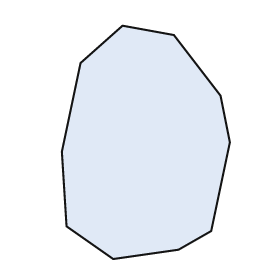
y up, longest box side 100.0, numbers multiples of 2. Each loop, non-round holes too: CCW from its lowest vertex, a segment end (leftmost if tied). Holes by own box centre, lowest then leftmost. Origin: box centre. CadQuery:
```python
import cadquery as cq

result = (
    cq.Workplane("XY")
    .moveTo(-14.0, -50.0)
    .lineTo(14.0, -46.0)
    .lineTo(28.0, -38.0)
    .lineTo(36.0, 0.0)
    .lineTo(32.0, 20.0)
    .lineTo(12.0, 46.0)
    .lineTo(-10.0, 50.0)
    .lineTo(-28.0, 34.0)
    .lineTo(-36.0, -4.0)
    .lineTo(-34.0, -36.0)
    .close()
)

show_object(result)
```